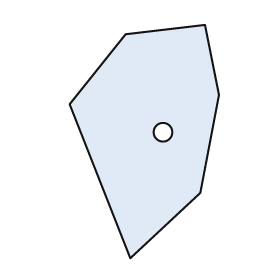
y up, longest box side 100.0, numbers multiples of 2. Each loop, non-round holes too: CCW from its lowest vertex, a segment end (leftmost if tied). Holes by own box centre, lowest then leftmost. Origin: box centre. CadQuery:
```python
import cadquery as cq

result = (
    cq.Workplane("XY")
    .moveTo(-6.0, -50.0)
    .lineTo(24.0, -22.0)
    .lineTo(32.0, 20.0)
    .lineTo(26.0, 50.0)
    .lineTo(-8.0, 46.0)
    .lineTo(-32.0, 16.0)
    .close()
    .moveTo(8.0, 4.0)
    .circle(4.0)
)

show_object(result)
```